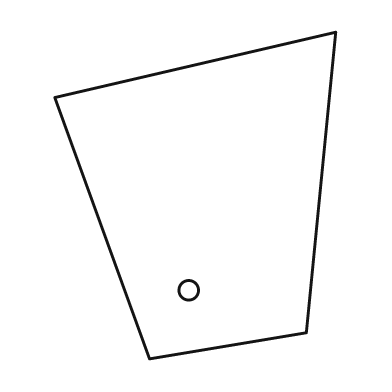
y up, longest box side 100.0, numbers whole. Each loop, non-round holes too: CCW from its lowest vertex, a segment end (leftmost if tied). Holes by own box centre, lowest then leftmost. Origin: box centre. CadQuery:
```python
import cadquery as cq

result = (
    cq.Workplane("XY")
    .moveTo(-14.0, -50.0)
    .lineTo(34.0, -42.0)
    .lineTo(43.0, 50.0)
    .lineTo(-43.0, 30.0)
    .close()
    .moveTo(-2.0, -29.0)
    .circle(3.0)
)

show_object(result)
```